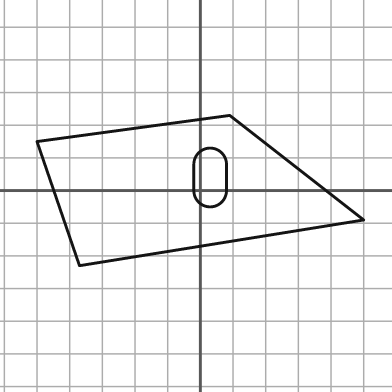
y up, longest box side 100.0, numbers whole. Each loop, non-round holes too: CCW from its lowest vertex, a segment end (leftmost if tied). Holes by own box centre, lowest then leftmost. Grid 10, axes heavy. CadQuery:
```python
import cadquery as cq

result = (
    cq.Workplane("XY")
    .moveTo(-37.0, -23.0)
    .lineTo(50.0, -9.0)
    .lineTo(9.0, 23.0)
    .lineTo(-50.0, 15.0)
    .close()
    .moveTo(-2.0, 0.0)
    .threePointArc((3.0, -5.0), (8.0, 0.0))
    .lineTo(8.0, 8.0)
    .threePointArc((3.0, 13.0), (-2.0, 8.0))
    .close()
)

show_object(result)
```